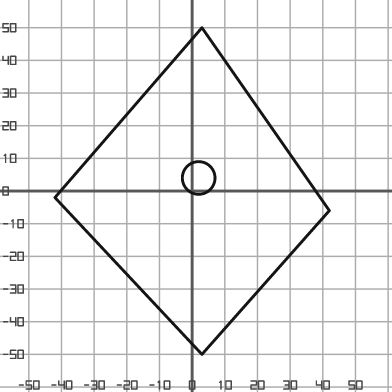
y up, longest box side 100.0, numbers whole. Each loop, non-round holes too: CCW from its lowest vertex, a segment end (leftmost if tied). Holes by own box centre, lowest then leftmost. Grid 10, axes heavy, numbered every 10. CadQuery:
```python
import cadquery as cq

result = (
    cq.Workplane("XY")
    .moveTo(3.0, -50.0)
    .lineTo(42.0, -6.0)
    .lineTo(3.0, 50.0)
    .lineTo(-42.0, -2.0)
    .close()
    .moveTo(2.0, 4.0)
    .circle(5.0)
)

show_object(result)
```